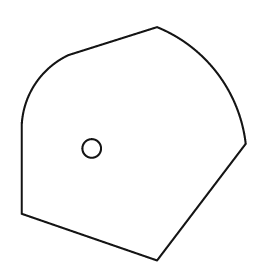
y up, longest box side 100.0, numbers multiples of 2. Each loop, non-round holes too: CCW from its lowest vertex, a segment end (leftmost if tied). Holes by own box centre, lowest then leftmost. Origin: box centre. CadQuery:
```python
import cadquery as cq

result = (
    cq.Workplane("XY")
    .moveTo(10.0, -50.0)
    .lineTo(48.0, 0.0)
    .threePointArc((36.0, 30.0), (10.0, 50.0))
    .lineTo(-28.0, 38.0)
    .threePointArc((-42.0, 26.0), (-48.0, 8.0))
    .lineTo(-48.0, -30.0)
    .close()
    .moveTo(-18.0, -2.0)
    .circle(4.0)
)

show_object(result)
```